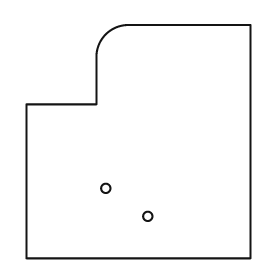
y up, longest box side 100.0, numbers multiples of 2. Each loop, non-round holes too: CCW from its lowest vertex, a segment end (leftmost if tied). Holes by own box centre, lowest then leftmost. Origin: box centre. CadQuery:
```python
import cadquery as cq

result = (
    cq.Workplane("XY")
    .moveTo(-48.0, -50.0)
    .lineTo(48.0, -50.0)
    .lineTo(48.0, 50.0)
    .lineTo(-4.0, 50.0)
    .threePointArc((-14.0, 46.0), (-18.0, 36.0))
    .lineTo(-18.0, 16.0)
    .lineTo(-48.0, 16.0)
    .close()
    .moveTo(4.0, -32.0)
    .circle(2.0)
    .moveTo(-14.0, -20.0)
    .circle(2.0)
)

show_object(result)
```